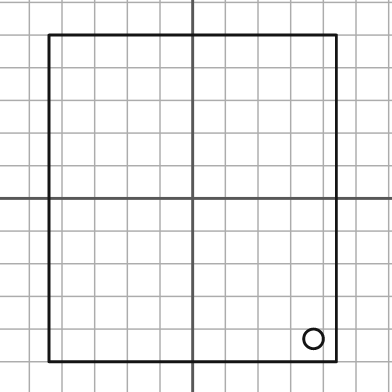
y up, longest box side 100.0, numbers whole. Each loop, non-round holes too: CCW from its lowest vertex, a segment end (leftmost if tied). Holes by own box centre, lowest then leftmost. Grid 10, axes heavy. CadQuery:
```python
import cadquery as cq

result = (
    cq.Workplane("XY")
    .moveTo(-44.0, -50.0)
    .lineTo(44.0, -50.0)
    .lineTo(44.0, 50.0)
    .lineTo(-44.0, 50.0)
    .close()
    .moveTo(37.0, -43.0)
    .circle(3.0)
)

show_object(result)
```